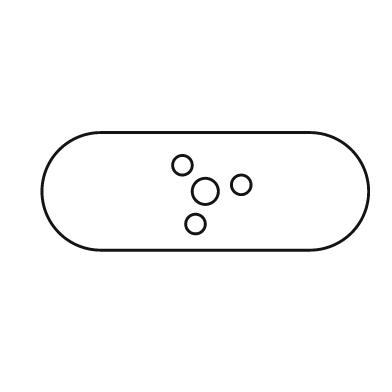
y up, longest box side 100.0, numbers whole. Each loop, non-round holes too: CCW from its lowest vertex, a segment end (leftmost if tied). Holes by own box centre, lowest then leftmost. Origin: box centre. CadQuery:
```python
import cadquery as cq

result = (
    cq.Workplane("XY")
    .moveTo(-32.0, -18.0)
    .lineTo(32.0, -18.0)
    .threePointArc((50.0, 0.0), (32.0, 18.0))
    .lineTo(-32.0, 18.0)
    .threePointArc((-50.0, 0.0), (-32.0, -18.0))
    .close()
    .moveTo(-3.0, -10.0)
    .circle(3.0)
    .moveTo(0.0, 0.0)
    .circle(4.0)
    .moveTo(11.0, 2.0)
    .circle(3.0)
    .moveTo(-7.0, 8.0)
    .circle(3.0)
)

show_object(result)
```